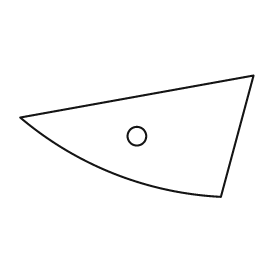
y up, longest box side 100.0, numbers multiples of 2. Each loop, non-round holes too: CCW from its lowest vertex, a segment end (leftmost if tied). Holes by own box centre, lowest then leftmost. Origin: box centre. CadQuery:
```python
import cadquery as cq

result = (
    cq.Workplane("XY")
    .moveTo(36.0, -26.0)
    .lineTo(50.0, 26.0)
    .lineTo(-50.0, 8.0)
    .threePointArc((-10.0, -16.0), (36.0, -26.0))
    .close()
    .moveTo(0.0, 0.0)
    .circle(4.0)
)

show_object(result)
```